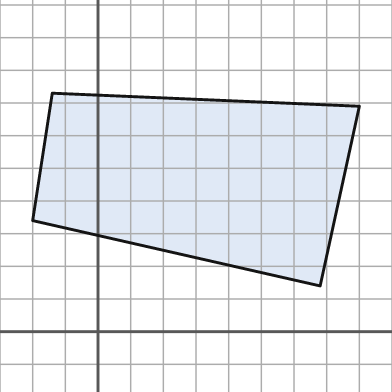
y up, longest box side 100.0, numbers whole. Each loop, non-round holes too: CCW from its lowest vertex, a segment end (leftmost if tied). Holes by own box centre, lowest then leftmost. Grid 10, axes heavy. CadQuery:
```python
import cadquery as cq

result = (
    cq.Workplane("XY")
    .moveTo(68.0, 14.0)
    .lineTo(80.0, 69.0)
    .lineTo(-14.0, 73.0)
    .lineTo(-20.0, 34.0)
    .close()
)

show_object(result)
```